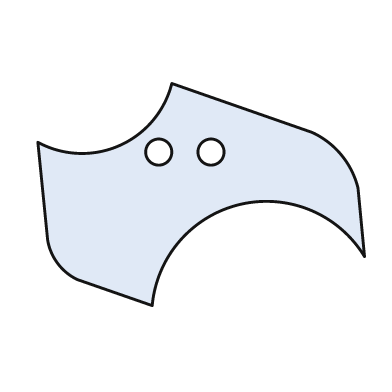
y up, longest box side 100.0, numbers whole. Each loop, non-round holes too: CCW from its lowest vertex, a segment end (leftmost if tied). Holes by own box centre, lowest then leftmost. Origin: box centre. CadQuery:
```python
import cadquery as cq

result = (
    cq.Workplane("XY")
    .moveTo(-15.0, -34.0)
    .threePointArc((12.0, -3.0), (50.0, -19.0))
    .lineTo(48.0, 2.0)
    .threePointArc((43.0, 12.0), (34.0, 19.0))
    .lineTo(-9.0, 34.0)
    .threePointArc((-25.0, 15.0), (-50.0, 16.0))
    .lineTo(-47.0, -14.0)
    .threePointArc((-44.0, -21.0), (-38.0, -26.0))
    .close()
    .moveTo(-13.0, 13.0)
    .circle(4.0)
    .moveTo(3.0, 13.0)
    .circle(4.0)
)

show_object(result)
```